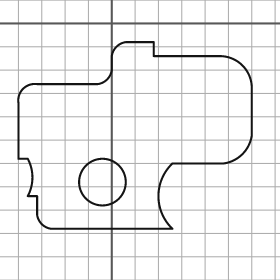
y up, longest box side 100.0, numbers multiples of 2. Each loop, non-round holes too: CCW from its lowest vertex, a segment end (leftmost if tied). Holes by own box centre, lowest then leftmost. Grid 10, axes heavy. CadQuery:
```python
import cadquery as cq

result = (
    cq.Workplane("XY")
    .moveTo(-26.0, -88.0)
    .lineTo(26.0, -88.0)
    .threePointArc((20.0, -74.0), (26.0, -60.0))
    .lineTo(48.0, -60.0)
    .threePointArc((56.0, -56.0), (60.0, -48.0))
    .lineTo(60.0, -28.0)
    .threePointArc((56.0, -18.0), (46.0, -14.0))
    .lineTo(18.0, -14.0)
    .lineTo(18.0, -8.0)
    .lineTo(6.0, -8.0)
    .threePointArc((2.0, -10.0), (0.0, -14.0))
    .lineTo(0.0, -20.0)
    .threePointArc((-2.0, -24.0), (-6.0, -26.0))
    .lineTo(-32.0, -26.0)
    .threePointArc((-38.0, -28.0), (-40.0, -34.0))
    .lineTo(-40.0, -58.0)
    .lineTo(-36.0, -58.0)
    .threePointArc((-34.0, -66.0), (-36.0, -74.0))
    .lineTo(-32.0, -74.0)
    .lineTo(-32.0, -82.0)
    .threePointArc((-30.0, -86.0), (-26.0, -88.0))
    .close()
    .moveTo(-4.0, -68.0)
    .circle(10.0)
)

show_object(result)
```